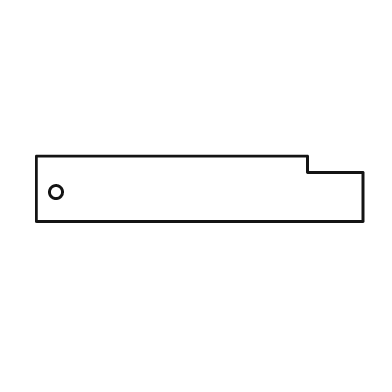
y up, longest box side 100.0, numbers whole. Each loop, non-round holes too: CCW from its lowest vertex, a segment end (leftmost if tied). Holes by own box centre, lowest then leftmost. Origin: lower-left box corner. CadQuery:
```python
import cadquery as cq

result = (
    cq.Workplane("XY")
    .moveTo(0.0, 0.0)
    .lineTo(100.0, 0.0)
    .lineTo(100.0, 15.0)
    .lineTo(83.0, 15.0)
    .lineTo(83.0, 20.0)
    .lineTo(0.0, 20.0)
    .close()
    .moveTo(6.0, 9.0)
    .circle(2.0)
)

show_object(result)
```